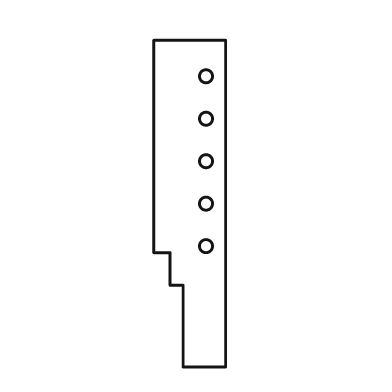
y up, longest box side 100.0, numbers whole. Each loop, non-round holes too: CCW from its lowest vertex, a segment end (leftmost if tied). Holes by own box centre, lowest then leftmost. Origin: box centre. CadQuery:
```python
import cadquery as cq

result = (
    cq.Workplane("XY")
    .moveTo(-2.0, -50.0)
    .lineTo(11.0, -50.0)
    .lineTo(11.0, 50.0)
    .lineTo(-11.0, 50.0)
    .lineTo(-11.0, -15.0)
    .lineTo(-6.0, -15.0)
    .lineTo(-6.0, -25.0)
    .lineTo(-2.0, -25.0)
    .close()
    .moveTo(5.0, -13.0)
    .circle(2.0)
    .moveTo(5.0, 0.0)
    .circle(2.0)
    .moveTo(5.0, 13.0)
    .circle(2.0)
    .moveTo(5.0, 26.0)
    .circle(2.0)
    .moveTo(5.0, 39.0)
    .circle(2.0)
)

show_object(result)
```